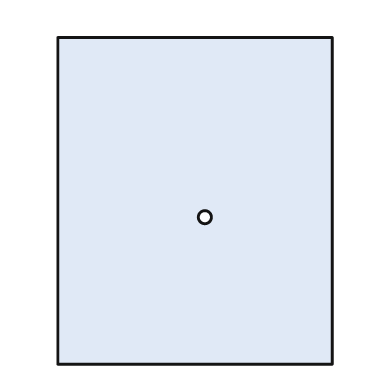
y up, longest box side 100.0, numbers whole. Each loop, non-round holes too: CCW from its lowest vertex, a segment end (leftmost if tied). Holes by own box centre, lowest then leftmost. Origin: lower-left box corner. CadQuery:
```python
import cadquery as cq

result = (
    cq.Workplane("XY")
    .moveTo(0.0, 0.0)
    .lineTo(84.0, 0.0)
    .lineTo(84.0, 100.0)
    .lineTo(0.0, 100.0)
    .close()
    .moveTo(45.0, 45.0)
    .circle(2.0)
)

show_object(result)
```